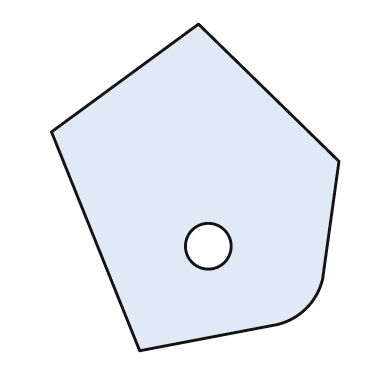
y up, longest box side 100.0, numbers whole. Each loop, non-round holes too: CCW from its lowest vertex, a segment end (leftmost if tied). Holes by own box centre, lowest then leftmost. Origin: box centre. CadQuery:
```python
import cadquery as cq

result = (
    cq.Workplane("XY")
    .moveTo(-17.0, -50.0)
    .lineTo(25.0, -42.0)
    .threePointArc((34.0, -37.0), (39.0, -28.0))
    .lineTo(44.0, 8.0)
    .lineTo(1.0, 50.0)
    .lineTo(-44.0, 17.0)
    .close()
    .moveTo(4.0, -18.0)
    .circle(7.0)
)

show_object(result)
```